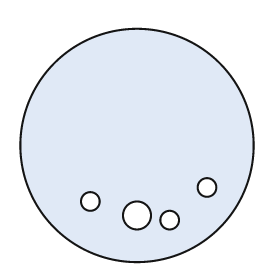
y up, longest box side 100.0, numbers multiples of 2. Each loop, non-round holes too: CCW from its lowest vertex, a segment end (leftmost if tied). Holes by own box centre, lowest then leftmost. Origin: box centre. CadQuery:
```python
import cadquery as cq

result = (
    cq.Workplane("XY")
    .moveTo(0.0, 0.0)
    .circle(50.0)
    .moveTo(14.0, -32.0)
    .circle(4.0)
    .moveTo(0.0, -30.0)
    .circle(6.0)
    .moveTo(-20.0, -24.0)
    .circle(4.0)
    .moveTo(30.0, -18.0)
    .circle(4.0)
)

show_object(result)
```